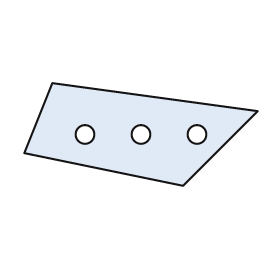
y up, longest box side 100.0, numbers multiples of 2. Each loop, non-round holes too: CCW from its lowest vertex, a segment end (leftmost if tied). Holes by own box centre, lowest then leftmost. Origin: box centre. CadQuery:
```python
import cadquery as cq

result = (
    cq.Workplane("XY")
    .moveTo(18.0, -22.0)
    .lineTo(50.0, 10.0)
    .lineTo(-38.0, 22.0)
    .lineTo(-50.0, -8.0)
    .close()
    .moveTo(-24.0, 0.0)
    .circle(4.0)
    .moveTo(0.0, 0.0)
    .circle(4.0)
    .moveTo(24.0, 0.0)
    .circle(4.0)
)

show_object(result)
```